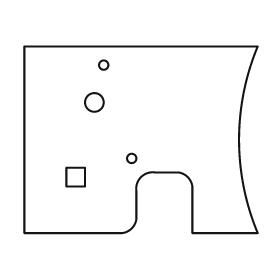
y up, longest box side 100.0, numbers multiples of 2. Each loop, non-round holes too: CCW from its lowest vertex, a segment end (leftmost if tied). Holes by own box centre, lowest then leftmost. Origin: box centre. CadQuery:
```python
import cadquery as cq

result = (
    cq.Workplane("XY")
    .moveTo(-50.0, -40.0)
    .lineTo(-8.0, -40.0)
    .threePointArc((-4.0, -38.0), (-2.0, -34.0))
    .lineTo(-2.0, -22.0)
    .threePointArc((0.0, -16.0), (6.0, -14.0))
    .lineTo(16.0, -14.0)
    .threePointArc((20.0, -16.0), (22.0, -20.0))
    .lineTo(22.0, -40.0)
    .lineTo(50.0, -40.0)
    .threePointArc((42.0, 0.0), (50.0, 40.0))
    .lineTo(-50.0, 40.0)
    .close()
    .moveTo(-32.0, -20.0)
    .lineTo(-24.0, -20.0)
    .lineTo(-24.0, -12.0)
    .lineTo(-32.0, -12.0)
    .close()
    .moveTo(-4.0, -8.0)
    .circle(2.0)
    .moveTo(-20.0, 16.0)
    .circle(4.0)
    .moveTo(-16.0, 32.0)
    .circle(2.0)
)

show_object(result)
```